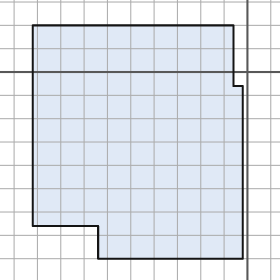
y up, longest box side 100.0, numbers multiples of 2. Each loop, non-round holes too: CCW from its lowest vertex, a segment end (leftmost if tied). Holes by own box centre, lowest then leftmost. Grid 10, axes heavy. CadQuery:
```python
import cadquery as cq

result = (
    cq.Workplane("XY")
    .moveTo(-64.0, -80.0)
    .lineTo(-2.0, -80.0)
    .lineTo(-2.0, -6.0)
    .lineTo(-6.0, -6.0)
    .lineTo(-6.0, 20.0)
    .lineTo(-92.0, 20.0)
    .lineTo(-92.0, -66.0)
    .lineTo(-64.0, -66.0)
    .close()
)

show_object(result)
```